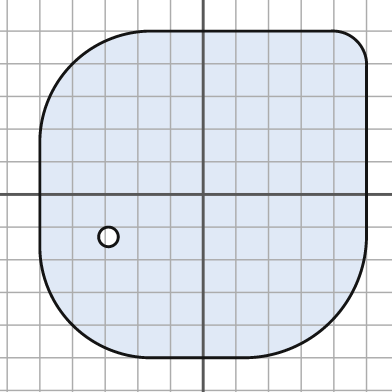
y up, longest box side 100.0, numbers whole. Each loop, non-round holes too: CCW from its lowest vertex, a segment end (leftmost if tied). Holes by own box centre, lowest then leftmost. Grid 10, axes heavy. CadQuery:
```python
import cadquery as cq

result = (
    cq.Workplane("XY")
    .moveTo(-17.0, -50.0)
    .lineTo(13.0, -50.0)
    .threePointArc((39.0, -39.0), (50.0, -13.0))
    .lineTo(50.0, 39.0)
    .threePointArc((47.0, 47.0), (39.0, 50.0))
    .lineTo(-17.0, 50.0)
    .threePointArc((-40.0, 40.0), (-50.0, 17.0))
    .lineTo(-50.0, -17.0)
    .threePointArc((-40.0, -40.0), (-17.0, -50.0))
    .close()
    .moveTo(-29.0, -13.0)
    .circle(3.0)
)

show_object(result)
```